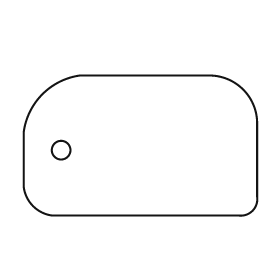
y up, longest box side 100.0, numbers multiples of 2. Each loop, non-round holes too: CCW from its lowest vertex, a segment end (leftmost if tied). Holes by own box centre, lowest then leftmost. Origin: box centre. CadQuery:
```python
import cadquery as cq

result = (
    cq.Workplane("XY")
    .moveTo(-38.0, -30.0)
    .lineTo(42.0, -30.0)
    .threePointArc((48.0, -28.0), (50.0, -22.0))
    .lineTo(50.0, 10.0)
    .threePointArc((44.0, 24.0), (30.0, 30.0))
    .lineTo(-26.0, 30.0)
    .threePointArc((-42.0, 22.0), (-50.0, 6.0))
    .lineTo(-50.0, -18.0)
    .threePointArc((-46.0, -26.0), (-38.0, -30.0))
    .close()
    .moveTo(-34.0, -2.0)
    .circle(4.0)
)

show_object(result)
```